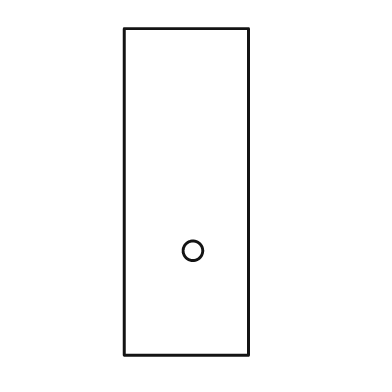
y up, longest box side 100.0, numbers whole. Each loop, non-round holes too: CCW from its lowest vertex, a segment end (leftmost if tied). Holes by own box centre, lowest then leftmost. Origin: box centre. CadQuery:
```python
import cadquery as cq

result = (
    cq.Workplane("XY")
    .moveTo(-19.0, -50.0)
    .lineTo(19.0, -50.0)
    .lineTo(19.0, 50.0)
    .lineTo(-19.0, 50.0)
    .close()
    .moveTo(2.0, -18.0)
    .circle(3.0)
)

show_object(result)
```